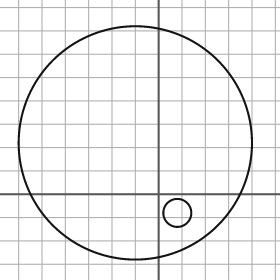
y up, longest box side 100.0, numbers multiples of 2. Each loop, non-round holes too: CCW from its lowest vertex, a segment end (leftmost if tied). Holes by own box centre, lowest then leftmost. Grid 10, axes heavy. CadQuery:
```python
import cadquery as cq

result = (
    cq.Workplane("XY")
    .moveTo(-10.0, 22.0)
    .circle(50.0)
    .moveTo(8.0, -8.0)
    .circle(6.0)
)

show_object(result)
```